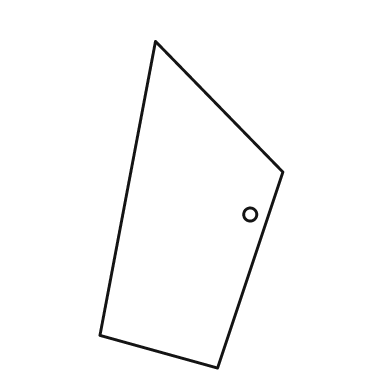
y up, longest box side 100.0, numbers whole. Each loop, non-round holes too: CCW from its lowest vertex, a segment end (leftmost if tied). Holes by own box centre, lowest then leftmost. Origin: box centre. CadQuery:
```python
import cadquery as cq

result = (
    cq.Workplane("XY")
    .moveTo(8.0, -50.0)
    .lineTo(28.0, 10.0)
    .lineTo(-11.0, 50.0)
    .lineTo(-28.0, -40.0)
    .close()
    .moveTo(18.0, -3.0)
    .circle(2.0)
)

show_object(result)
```